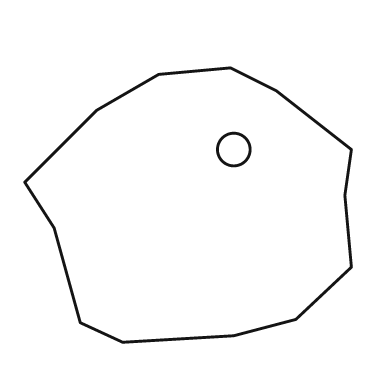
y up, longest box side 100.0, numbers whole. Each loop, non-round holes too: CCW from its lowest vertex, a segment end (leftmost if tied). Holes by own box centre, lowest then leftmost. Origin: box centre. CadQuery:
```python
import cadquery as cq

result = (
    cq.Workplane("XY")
    .moveTo(-20.0, -42.0)
    .lineTo(14.0, -40.0)
    .lineTo(33.0, -35.0)
    .lineTo(50.0, -19.0)
    .lineTo(48.0, 3.0)
    .lineTo(50.0, 17.0)
    .lineTo(27.0, 35.0)
    .lineTo(13.0, 42.0)
    .lineTo(-9.0, 40.0)
    .lineTo(-28.0, 29.0)
    .lineTo(-50.0, 7.0)
    .lineTo(-41.0, -7.0)
    .lineTo(-33.0, -36.0)
    .close()
    .moveTo(14.0, 17.0)
    .circle(5.0)
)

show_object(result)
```